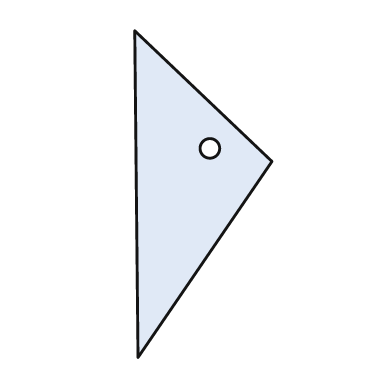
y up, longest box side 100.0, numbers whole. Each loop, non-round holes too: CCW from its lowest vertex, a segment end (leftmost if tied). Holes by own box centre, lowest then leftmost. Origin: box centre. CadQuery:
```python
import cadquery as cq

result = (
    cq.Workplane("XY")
    .moveTo(-20.0, -50.0)
    .lineTo(21.0, 10.0)
    .lineTo(-21.0, 50.0)
    .close()
    .moveTo(2.0, 14.0)
    .circle(3.0)
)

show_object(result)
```